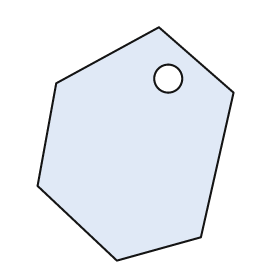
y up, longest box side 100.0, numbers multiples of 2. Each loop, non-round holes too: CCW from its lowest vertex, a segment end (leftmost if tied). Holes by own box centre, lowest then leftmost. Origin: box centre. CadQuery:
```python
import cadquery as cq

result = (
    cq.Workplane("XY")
    .moveTo(-8.0, -50.0)
    .lineTo(28.0, -40.0)
    .lineTo(42.0, 22.0)
    .lineTo(10.0, 50.0)
    .lineTo(-34.0, 26.0)
    .lineTo(-42.0, -18.0)
    .close()
    .moveTo(14.0, 28.0)
    .circle(6.0)
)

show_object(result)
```